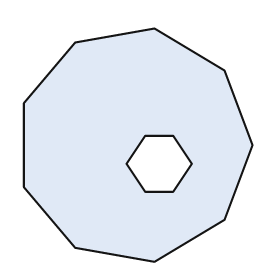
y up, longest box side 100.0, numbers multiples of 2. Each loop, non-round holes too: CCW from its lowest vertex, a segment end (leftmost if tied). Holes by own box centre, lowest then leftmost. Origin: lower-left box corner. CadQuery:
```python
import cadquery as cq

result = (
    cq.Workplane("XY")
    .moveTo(56.0, 0.0)
    .lineTo(86.0, 18.0)
    .lineTo(98.0, 50.0)
    .lineTo(86.0, 82.0)
    .lineTo(56.0, 100.0)
    .lineTo(22.0, 94.0)
    .lineTo(0.0, 68.0)
    .lineTo(0.0, 32.0)
    .lineTo(22.0, 6.0)
    .close()
    .moveTo(52.0, 30.0)
    .lineTo(64.0, 30.0)
    .lineTo(72.0, 42.0)
    .lineTo(64.0, 54.0)
    .lineTo(52.0, 54.0)
    .lineTo(44.0, 42.0)
    .close()
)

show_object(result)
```